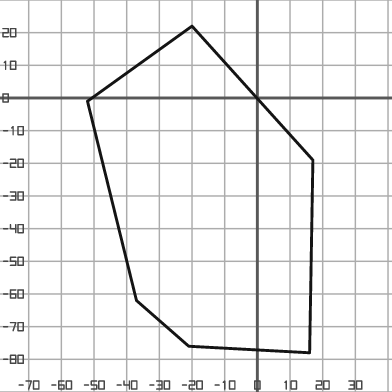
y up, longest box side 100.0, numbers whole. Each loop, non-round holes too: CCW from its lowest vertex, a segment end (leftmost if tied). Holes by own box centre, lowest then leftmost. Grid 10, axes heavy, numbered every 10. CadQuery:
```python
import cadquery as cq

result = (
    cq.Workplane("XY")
    .moveTo(16.0, -78.0)
    .lineTo(17.0, -19.0)
    .lineTo(-20.0, 22.0)
    .lineTo(-52.0, -1.0)
    .lineTo(-37.0, -62.0)
    .lineTo(-21.0, -76.0)
    .close()
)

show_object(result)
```